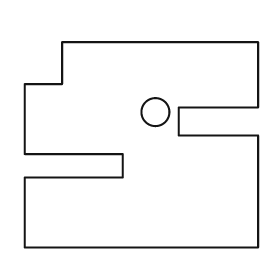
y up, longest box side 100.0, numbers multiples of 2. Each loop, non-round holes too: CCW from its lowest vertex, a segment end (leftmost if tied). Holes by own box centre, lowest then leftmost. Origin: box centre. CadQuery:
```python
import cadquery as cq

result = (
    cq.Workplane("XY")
    .moveTo(-50.0, -44.0)
    .lineTo(50.0, -44.0)
    .lineTo(50.0, 4.0)
    .lineTo(16.0, 4.0)
    .lineTo(16.0, 16.0)
    .lineTo(50.0, 16.0)
    .lineTo(50.0, 44.0)
    .lineTo(-34.0, 44.0)
    .lineTo(-34.0, 26.0)
    .lineTo(-50.0, 26.0)
    .lineTo(-50.0, -4.0)
    .lineTo(-8.0, -4.0)
    .lineTo(-8.0, -14.0)
    .lineTo(-50.0, -14.0)
    .close()
    .moveTo(6.0, 14.0)
    .circle(6.0)
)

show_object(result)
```